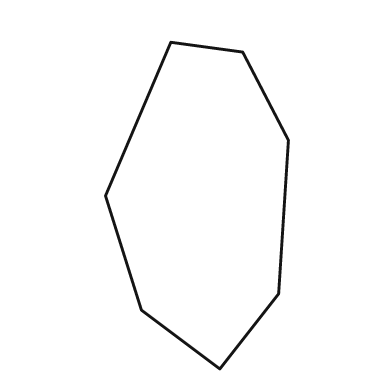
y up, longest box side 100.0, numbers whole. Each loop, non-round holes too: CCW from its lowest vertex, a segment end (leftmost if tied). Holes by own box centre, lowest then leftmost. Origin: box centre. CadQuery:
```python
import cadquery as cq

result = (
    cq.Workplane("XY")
    .moveTo(7.0, -50.0)
    .lineTo(25.0, -27.0)
    .lineTo(28.0, 20.0)
    .lineTo(14.0, 47.0)
    .lineTo(-8.0, 50.0)
    .lineTo(-28.0, 3.0)
    .lineTo(-17.0, -32.0)
    .close()
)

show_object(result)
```